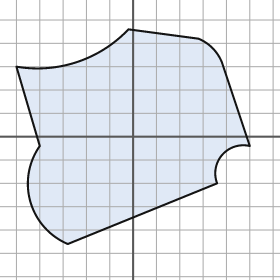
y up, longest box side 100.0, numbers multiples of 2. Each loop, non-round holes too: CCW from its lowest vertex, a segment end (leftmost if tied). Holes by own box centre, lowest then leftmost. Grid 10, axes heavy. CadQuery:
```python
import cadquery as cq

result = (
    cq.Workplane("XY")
    .moveTo(-28.0, -46.0)
    .lineTo(36.0, -20.0)
    .threePointArc((38.0, -8.0), (50.0, -4.0))
    .lineTo(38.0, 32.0)
    .threePointArc((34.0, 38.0), (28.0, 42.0))
    .lineTo(-2.0, 46.0)
    .threePointArc((-24.0, 32.0), (-50.0, 30.0))
    .lineTo(-40.0, -4.0)
    .threePointArc((-44.0, -28.0), (-28.0, -46.0))
    .close()
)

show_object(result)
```